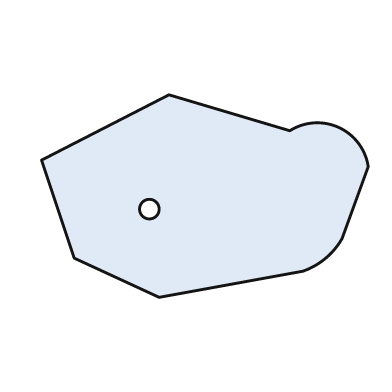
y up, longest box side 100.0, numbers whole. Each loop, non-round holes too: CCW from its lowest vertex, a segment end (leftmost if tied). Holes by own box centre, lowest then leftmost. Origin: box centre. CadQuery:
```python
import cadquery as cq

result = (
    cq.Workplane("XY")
    .moveTo(-14.0, -31.0)
    .lineTo(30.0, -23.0)
    .threePointArc((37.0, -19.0), (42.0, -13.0))
    .lineTo(50.0, 9.0)
    .threePointArc((41.0, 21.0), (26.0, 20.0))
    .lineTo(-11.0, 31.0)
    .lineTo(-50.0, 11.0)
    .lineTo(-40.0, -19.0)
    .close()
    .moveTo(-17.0, -4.0)
    .circle(3.0)
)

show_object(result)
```